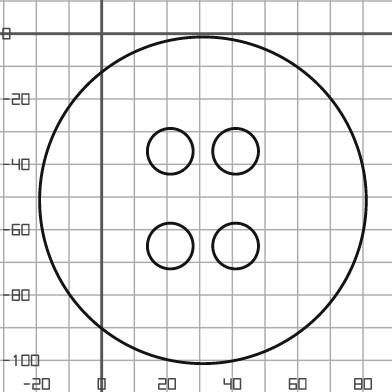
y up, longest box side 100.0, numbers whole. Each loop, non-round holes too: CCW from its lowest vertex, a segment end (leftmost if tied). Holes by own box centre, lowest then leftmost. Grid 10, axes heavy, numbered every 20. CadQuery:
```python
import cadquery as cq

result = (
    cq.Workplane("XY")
    .moveTo(31.0, -51.0)
    .circle(50.0)
    .moveTo(21.0, -65.0)
    .circle(7.0)
    .moveTo(41.0, -65.0)
    .circle(7.0)
    .moveTo(21.0, -36.0)
    .circle(7.0)
    .moveTo(41.0, -36.0)
    .circle(7.0)
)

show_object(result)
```